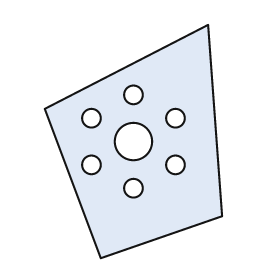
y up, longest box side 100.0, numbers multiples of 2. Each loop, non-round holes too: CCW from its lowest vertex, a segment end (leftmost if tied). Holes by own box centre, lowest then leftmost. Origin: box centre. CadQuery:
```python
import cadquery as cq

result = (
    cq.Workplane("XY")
    .moveTo(-14.0, -50.0)
    .lineTo(38.0, -32.0)
    .lineTo(32.0, 50.0)
    .lineTo(-38.0, 14.0)
    .close()
    .moveTo(0.0, -20.0)
    .circle(4.0)
    .moveTo(-18.0, -10.0)
    .circle(4.0)
    .moveTo(18.0, -10.0)
    .circle(4.0)
    .moveTo(0.0, 0.0)
    .circle(8.0)
    .moveTo(-18.0, 10.0)
    .circle(4.0)
    .moveTo(18.0, 10.0)
    .circle(4.0)
    .moveTo(0.0, 20.0)
    .circle(4.0)
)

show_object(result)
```